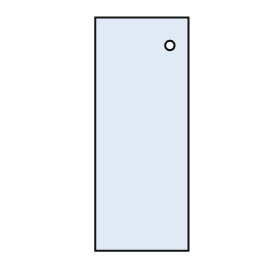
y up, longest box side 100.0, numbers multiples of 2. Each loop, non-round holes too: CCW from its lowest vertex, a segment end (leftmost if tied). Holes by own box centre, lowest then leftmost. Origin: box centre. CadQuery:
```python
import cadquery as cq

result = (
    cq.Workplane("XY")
    .moveTo(-20.0, -50.0)
    .lineTo(20.0, -50.0)
    .lineTo(20.0, 50.0)
    .lineTo(-20.0, 50.0)
    .close()
    .moveTo(12.0, 38.0)
    .circle(2.0)
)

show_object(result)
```